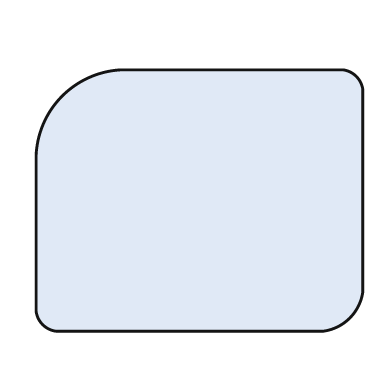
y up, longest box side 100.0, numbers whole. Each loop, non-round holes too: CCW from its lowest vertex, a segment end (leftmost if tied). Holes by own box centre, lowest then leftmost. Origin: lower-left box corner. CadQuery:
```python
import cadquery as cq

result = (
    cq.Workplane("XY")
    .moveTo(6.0, 0.0)
    .lineTo(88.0, 0.0)
    .threePointArc((96.0, 4.0), (100.0, 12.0))
    .lineTo(100.0, 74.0)
    .threePointArc((98.0, 78.0), (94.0, 80.0))
    .lineTo(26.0, 80.0)
    .threePointArc((8.0, 72.0), (0.0, 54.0))
    .lineTo(0.0, 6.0)
    .threePointArc((2.0, 2.0), (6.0, 0.0))
    .close()
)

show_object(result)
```